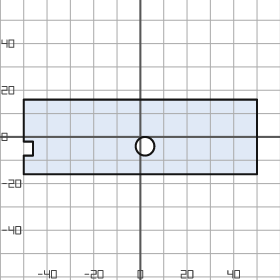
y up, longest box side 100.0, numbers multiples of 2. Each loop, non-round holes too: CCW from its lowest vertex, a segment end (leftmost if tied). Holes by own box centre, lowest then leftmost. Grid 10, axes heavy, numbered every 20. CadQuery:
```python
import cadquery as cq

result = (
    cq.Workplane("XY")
    .moveTo(-50.0, -16.0)
    .lineTo(50.0, -16.0)
    .lineTo(50.0, 16.0)
    .lineTo(-50.0, 16.0)
    .lineTo(-50.0, -2.0)
    .lineTo(-46.0, -2.0)
    .lineTo(-46.0, -8.0)
    .lineTo(-50.0, -8.0)
    .close()
    .moveTo(2.0, -4.0)
    .circle(4.0)
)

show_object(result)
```